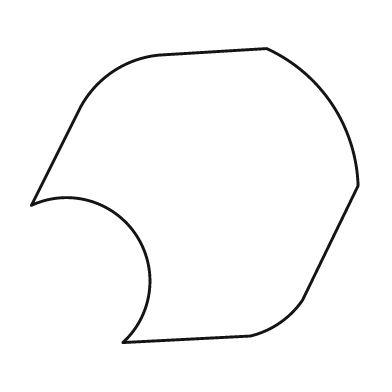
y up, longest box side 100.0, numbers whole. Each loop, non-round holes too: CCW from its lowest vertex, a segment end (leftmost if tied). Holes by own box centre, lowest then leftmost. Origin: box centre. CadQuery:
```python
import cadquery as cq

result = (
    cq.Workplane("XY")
    .moveTo(-22.0, -45.0)
    .lineTo(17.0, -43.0)
    .threePointArc((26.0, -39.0), (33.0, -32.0))
    .lineTo(50.0, 3.0)
    .threePointArc((42.0, 28.0), (22.0, 45.0))
    .lineTo(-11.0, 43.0)
    .threePointArc((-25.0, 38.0), (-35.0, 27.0))
    .lineTo(-50.0, -3.0)
    .threePointArc((-18.0, -12.0), (-22.0, -45.0))
    .close()
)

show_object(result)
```